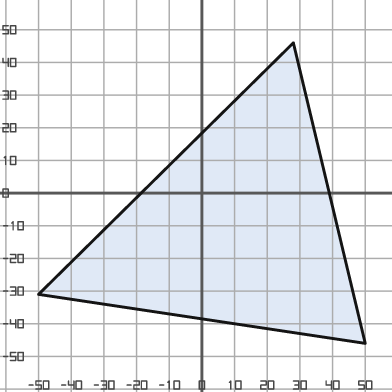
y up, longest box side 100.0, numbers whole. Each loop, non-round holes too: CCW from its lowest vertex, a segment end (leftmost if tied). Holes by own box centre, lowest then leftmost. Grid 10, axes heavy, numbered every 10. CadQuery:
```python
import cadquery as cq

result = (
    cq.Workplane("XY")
    .moveTo(50.0, -46.0)
    .lineTo(28.0, 46.0)
    .lineTo(-50.0, -31.0)
    .close()
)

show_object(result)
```